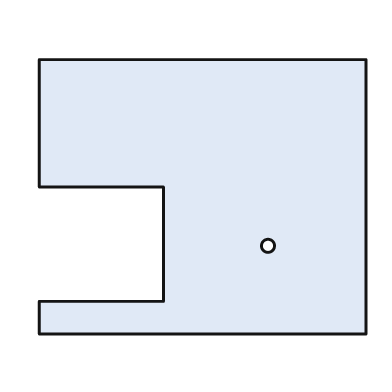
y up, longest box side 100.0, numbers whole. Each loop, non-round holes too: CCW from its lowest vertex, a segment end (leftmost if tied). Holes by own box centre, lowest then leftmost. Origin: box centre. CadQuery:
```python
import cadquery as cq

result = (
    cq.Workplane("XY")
    .moveTo(-50.0, -42.0)
    .lineTo(50.0, -42.0)
    .lineTo(50.0, 42.0)
    .lineTo(-50.0, 42.0)
    .lineTo(-50.0, 3.0)
    .lineTo(-12.0, 3.0)
    .lineTo(-12.0, -32.0)
    .lineTo(-50.0, -32.0)
    .close()
    .moveTo(20.0, -15.0)
    .circle(2.0)
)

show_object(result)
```